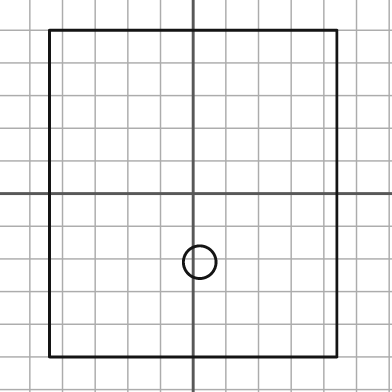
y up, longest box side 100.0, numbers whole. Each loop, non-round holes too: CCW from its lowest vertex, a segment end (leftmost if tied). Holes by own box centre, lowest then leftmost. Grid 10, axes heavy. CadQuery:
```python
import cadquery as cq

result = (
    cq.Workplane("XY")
    .moveTo(-44.0, -50.0)
    .lineTo(44.0, -50.0)
    .lineTo(44.0, 50.0)
    .lineTo(-44.0, 50.0)
    .close()
    .moveTo(2.0, -21.0)
    .circle(5.0)
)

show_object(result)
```